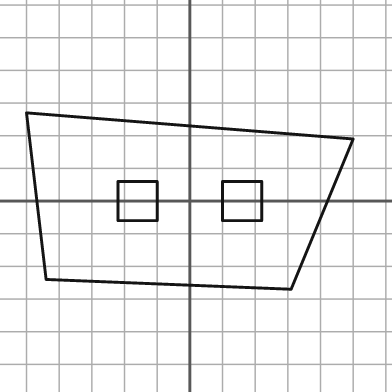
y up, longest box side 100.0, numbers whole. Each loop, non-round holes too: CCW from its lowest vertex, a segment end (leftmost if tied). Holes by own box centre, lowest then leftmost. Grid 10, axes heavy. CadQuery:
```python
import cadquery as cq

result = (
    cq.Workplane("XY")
    .moveTo(31.0, -27.0)
    .lineTo(50.0, 19.0)
    .lineTo(-50.0, 27.0)
    .lineTo(-44.0, -24.0)
    .close()
    .moveTo(-22.0, -6.0)
    .lineTo(-10.0, -6.0)
    .lineTo(-10.0, 6.0)
    .lineTo(-22.0, 6.0)
    .close()
    .moveTo(10.0, -6.0)
    .lineTo(22.0, -6.0)
    .lineTo(22.0, 6.0)
    .lineTo(10.0, 6.0)
    .close()
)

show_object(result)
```